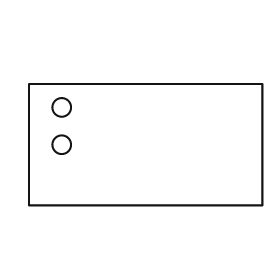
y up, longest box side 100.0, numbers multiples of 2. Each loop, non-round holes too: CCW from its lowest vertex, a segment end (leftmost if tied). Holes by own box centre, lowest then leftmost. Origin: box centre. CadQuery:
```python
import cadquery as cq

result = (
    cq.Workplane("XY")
    .moveTo(-50.0, -26.0)
    .lineTo(50.0, -26.0)
    .lineTo(50.0, 26.0)
    .lineTo(-50.0, 26.0)
    .close()
    .moveTo(-36.0, 0.0)
    .circle(4.0)
    .moveTo(-36.0, 16.0)
    .circle(4.0)
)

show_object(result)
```